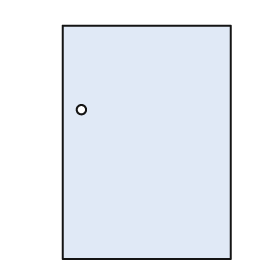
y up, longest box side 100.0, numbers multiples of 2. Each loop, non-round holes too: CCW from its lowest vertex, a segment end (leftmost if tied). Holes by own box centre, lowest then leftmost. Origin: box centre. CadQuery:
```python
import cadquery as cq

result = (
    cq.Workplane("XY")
    .moveTo(-36.0, -50.0)
    .lineTo(36.0, -50.0)
    .lineTo(36.0, 50.0)
    .lineTo(-36.0, 50.0)
    .close()
    .moveTo(-28.0, 14.0)
    .circle(2.0)
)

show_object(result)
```